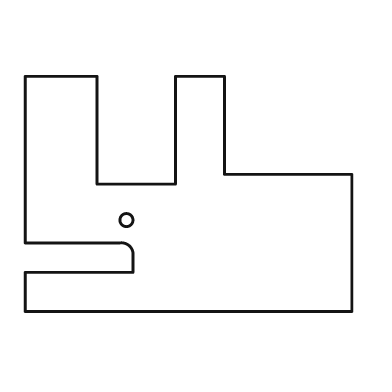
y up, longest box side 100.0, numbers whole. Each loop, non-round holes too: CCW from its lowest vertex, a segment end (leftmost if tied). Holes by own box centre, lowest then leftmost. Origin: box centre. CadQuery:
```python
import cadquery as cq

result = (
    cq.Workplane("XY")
    .moveTo(-50.0, -36.0)
    .lineTo(50.0, -36.0)
    .lineTo(50.0, 6.0)
    .lineTo(11.0, 6.0)
    .lineTo(11.0, 36.0)
    .lineTo(-4.0, 36.0)
    .lineTo(-4.0, 3.0)
    .lineTo(-28.0, 3.0)
    .lineTo(-28.0, 36.0)
    .lineTo(-50.0, 36.0)
    .lineTo(-50.0, -15.0)
    .lineTo(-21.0, -15.0)
    .threePointArc((-18.0, -16.0), (-17.0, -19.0))
    .lineTo(-17.0, -24.0)
    .lineTo(-50.0, -24.0)
    .close()
    .moveTo(-19.0, -8.0)
    .circle(2.0)
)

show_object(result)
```